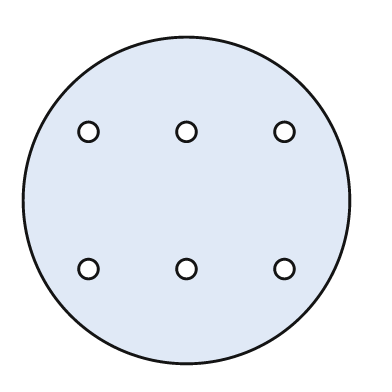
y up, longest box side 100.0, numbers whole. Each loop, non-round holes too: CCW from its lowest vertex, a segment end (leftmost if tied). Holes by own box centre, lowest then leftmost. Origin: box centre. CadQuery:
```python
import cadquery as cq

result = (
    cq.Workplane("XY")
    .moveTo(0.0, 0.0)
    .circle(50.0)
    .moveTo(-30.0, -21.0)
    .circle(3.0)
    .moveTo(0.0, -21.0)
    .circle(3.0)
    .moveTo(30.0, -21.0)
    .circle(3.0)
    .moveTo(-30.0, 21.0)
    .circle(3.0)
    .moveTo(0.0, 21.0)
    .circle(3.0)
    .moveTo(30.0, 21.0)
    .circle(3.0)
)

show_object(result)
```